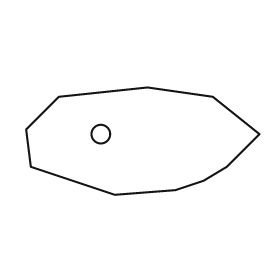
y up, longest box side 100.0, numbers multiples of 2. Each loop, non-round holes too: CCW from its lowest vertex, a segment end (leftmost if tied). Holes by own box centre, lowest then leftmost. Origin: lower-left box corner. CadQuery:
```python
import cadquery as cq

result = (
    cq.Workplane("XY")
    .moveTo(38.0, 0.0)
    .lineTo(64.0, 2.0)
    .lineTo(76.0, 6.0)
    .lineTo(86.0, 12.0)
    .lineTo(100.0, 26.0)
    .lineTo(80.0, 42.0)
    .lineTo(52.0, 46.0)
    .lineTo(14.0, 42.0)
    .lineTo(0.0, 28.0)
    .lineTo(2.0, 12.0)
    .close()
    .moveTo(32.0, 26.0)
    .circle(4.0)
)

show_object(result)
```